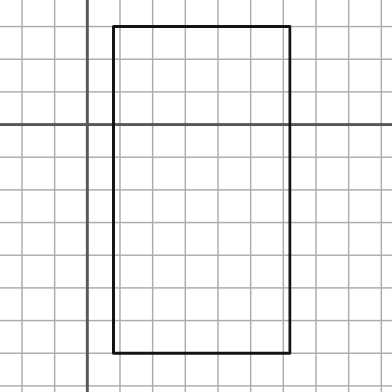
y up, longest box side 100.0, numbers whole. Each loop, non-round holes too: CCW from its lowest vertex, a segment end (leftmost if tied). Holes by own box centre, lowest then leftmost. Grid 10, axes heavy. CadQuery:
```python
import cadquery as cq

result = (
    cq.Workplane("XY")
    .moveTo(8.0, -70.0)
    .lineTo(62.0, -70.0)
    .lineTo(62.0, 30.0)
    .lineTo(8.0, 30.0)
    .close()
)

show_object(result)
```